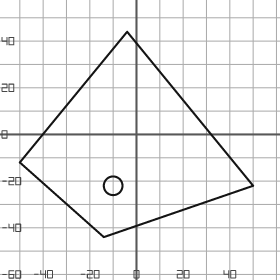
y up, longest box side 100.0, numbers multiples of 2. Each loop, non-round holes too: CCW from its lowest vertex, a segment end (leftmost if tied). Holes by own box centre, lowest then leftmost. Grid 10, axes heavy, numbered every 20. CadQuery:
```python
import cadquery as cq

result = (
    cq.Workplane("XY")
    .moveTo(-14.0, -44.0)
    .lineTo(50.0, -22.0)
    .lineTo(-4.0, 44.0)
    .lineTo(-50.0, -12.0)
    .close()
    .moveTo(-10.0, -22.0)
    .circle(4.0)
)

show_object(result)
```